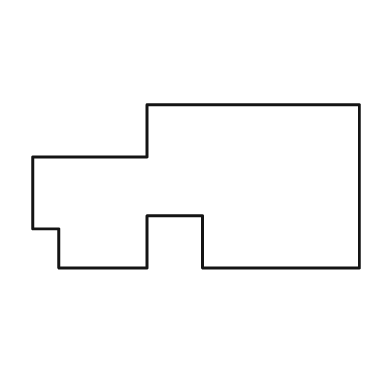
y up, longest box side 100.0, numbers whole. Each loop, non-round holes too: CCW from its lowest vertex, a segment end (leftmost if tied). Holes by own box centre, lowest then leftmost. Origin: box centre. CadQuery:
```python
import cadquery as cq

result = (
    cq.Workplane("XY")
    .moveTo(-42.0, -25.0)
    .lineTo(-15.0, -25.0)
    .lineTo(-15.0, -9.0)
    .lineTo(2.0, -9.0)
    .lineTo(2.0, -25.0)
    .lineTo(50.0, -25.0)
    .lineTo(50.0, 25.0)
    .lineTo(-15.0, 25.0)
    .lineTo(-15.0, 9.0)
    .lineTo(-50.0, 9.0)
    .lineTo(-50.0, -13.0)
    .lineTo(-42.0, -13.0)
    .close()
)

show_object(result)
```